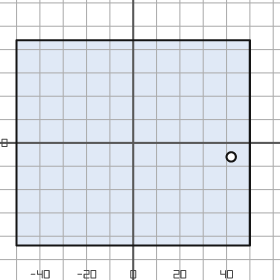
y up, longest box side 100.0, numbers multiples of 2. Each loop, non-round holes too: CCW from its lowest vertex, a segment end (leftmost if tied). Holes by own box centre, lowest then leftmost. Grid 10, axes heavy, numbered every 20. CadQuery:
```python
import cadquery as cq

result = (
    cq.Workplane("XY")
    .moveTo(-50.0, -44.0)
    .lineTo(50.0, -44.0)
    .lineTo(50.0, 44.0)
    .lineTo(-50.0, 44.0)
    .close()
    .moveTo(42.0, -6.0)
    .circle(2.0)
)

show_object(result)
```